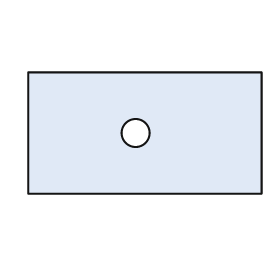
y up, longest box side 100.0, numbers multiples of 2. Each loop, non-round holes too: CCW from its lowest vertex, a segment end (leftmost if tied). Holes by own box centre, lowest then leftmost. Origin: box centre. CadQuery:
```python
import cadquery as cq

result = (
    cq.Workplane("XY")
    .moveTo(-50.0, -26.0)
    .lineTo(50.0, -26.0)
    .lineTo(50.0, 26.0)
    .lineTo(-50.0, 26.0)
    .close()
    .moveTo(-4.0, 0.0)
    .circle(6.0)
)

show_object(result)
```